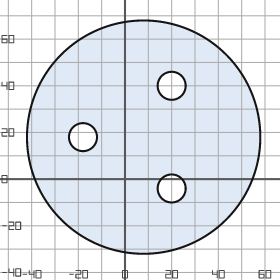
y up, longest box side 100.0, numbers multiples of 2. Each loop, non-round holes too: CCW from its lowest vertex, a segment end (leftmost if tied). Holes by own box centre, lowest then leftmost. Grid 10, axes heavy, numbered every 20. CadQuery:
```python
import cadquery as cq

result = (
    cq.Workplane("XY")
    .moveTo(8.0, 18.0)
    .circle(50.0)
    .moveTo(20.0, -4.0)
    .circle(6.0)
    .moveTo(-18.0, 18.0)
    .circle(6.0)
    .moveTo(20.0, 40.0)
    .circle(6.0)
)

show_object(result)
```